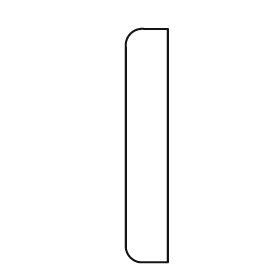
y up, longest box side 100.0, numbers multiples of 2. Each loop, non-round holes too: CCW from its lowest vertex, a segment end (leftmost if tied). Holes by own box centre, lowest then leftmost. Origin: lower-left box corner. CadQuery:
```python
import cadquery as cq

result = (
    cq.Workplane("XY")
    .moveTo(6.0, 0.0)
    .lineTo(18.0, 0.0)
    .lineTo(18.0, 100.0)
    .lineTo(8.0, 100.0)
    .threePointArc((2.0, 98.0), (0.0, 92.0))
    .lineTo(0.0, 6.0)
    .threePointArc((2.0, 2.0), (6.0, 0.0))
    .close()
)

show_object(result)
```